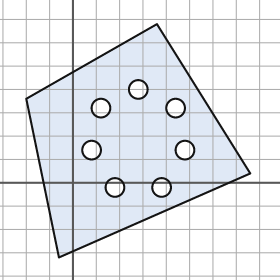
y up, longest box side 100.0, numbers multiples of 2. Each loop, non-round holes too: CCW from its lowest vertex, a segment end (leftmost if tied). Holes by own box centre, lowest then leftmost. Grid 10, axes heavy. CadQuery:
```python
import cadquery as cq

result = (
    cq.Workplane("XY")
    .moveTo(-6.0, -32.0)
    .lineTo(76.0, 4.0)
    .lineTo(36.0, 68.0)
    .lineTo(-20.0, 36.0)
    .close()
    .moveTo(18.0, -2.0)
    .circle(4.0)
    .moveTo(38.0, -2.0)
    .circle(4.0)
    .moveTo(8.0, 14.0)
    .circle(4.0)
    .moveTo(48.0, 14.0)
    .circle(4.0)
    .moveTo(12.0, 32.0)
    .circle(4.0)
    .moveTo(44.0, 32.0)
    .circle(4.0)
    .moveTo(28.0, 40.0)
    .circle(4.0)
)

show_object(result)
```